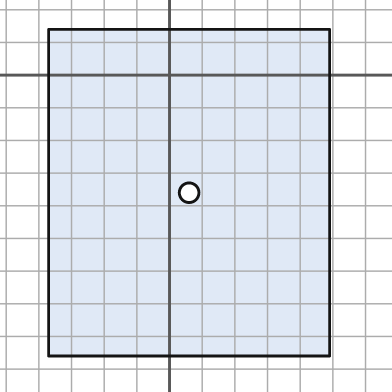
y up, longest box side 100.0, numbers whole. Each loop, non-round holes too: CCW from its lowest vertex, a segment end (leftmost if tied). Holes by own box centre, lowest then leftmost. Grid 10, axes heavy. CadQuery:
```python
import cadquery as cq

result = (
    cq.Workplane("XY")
    .moveTo(-37.0, -86.0)
    .lineTo(49.0, -86.0)
    .lineTo(49.0, 14.0)
    .lineTo(-37.0, 14.0)
    .close()
    .moveTo(6.0, -36.0)
    .circle(3.0)
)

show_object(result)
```